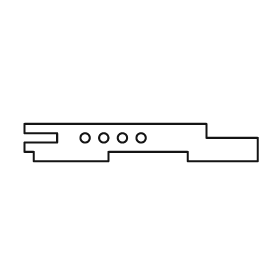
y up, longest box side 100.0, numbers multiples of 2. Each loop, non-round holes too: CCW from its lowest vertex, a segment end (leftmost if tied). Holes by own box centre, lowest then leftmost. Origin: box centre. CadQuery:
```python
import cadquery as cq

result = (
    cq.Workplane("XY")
    .moveTo(-46.0, -8.0)
    .lineTo(-14.0, -8.0)
    .lineTo(-14.0, -4.0)
    .lineTo(20.0, -4.0)
    .lineTo(20.0, -8.0)
    .lineTo(50.0, -8.0)
    .lineTo(50.0, 2.0)
    .lineTo(28.0, 2.0)
    .lineTo(28.0, 8.0)
    .lineTo(-50.0, 8.0)
    .lineTo(-50.0, 4.0)
    .lineTo(-36.0, 4.0)
    .lineTo(-36.0, 0.0)
    .lineTo(-50.0, 0.0)
    .lineTo(-50.0, -4.0)
    .lineTo(-46.0, -4.0)
    .close()
    .moveTo(-24.0, 2.0)
    .circle(2.0)
    .moveTo(-16.0, 2.0)
    .circle(2.0)
    .moveTo(-8.0, 2.0)
    .circle(2.0)
    .moveTo(0.0, 2.0)
    .circle(2.0)
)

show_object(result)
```